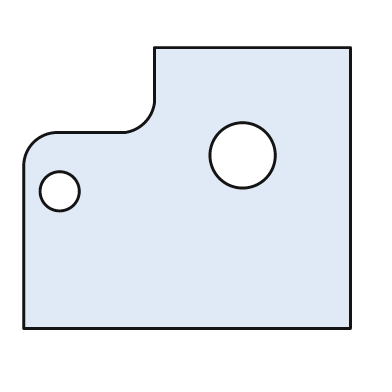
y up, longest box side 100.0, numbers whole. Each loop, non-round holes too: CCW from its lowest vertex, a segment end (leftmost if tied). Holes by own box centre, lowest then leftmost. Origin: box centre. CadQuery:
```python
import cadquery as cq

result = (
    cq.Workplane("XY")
    .moveTo(-50.0, -43.0)
    .lineTo(50.0, -43.0)
    .lineTo(50.0, 43.0)
    .lineTo(-10.0, 43.0)
    .lineTo(-10.0, 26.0)
    .threePointArc((-13.0, 20.0), (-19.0, 17.0))
    .lineTo(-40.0, 17.0)
    .threePointArc((-47.0, 14.0), (-50.0, 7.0))
    .close()
    .moveTo(-39.0, -1.0)
    .circle(6.0)
    .moveTo(17.0, 10.0)
    .circle(10.0)
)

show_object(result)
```